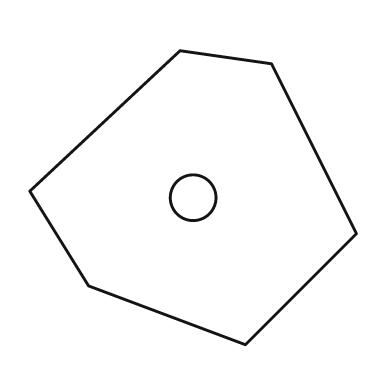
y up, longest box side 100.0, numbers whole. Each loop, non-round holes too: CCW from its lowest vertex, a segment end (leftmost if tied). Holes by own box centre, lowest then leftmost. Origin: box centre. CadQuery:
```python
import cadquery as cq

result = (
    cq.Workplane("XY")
    .moveTo(16.0, -45.0)
    .lineTo(50.0, -11.0)
    .lineTo(24.0, 41.0)
    .lineTo(-4.0, 45.0)
    .lineTo(-50.0, 2.0)
    .lineTo(-32.0, -27.0)
    .close()
    .moveTo(0.0, 0.0)
    .circle(7.0)
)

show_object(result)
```